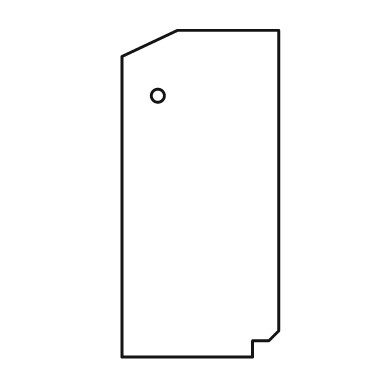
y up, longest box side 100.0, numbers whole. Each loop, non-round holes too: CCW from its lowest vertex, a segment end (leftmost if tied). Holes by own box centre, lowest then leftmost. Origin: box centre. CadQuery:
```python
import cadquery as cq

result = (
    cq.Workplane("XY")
    .moveTo(-24.0, -50.0)
    .lineTo(16.0, -50.0)
    .lineTo(16.0, -45.0)
    .lineTo(21.0, -45.0)
    .lineTo(24.0, -42.0)
    .lineTo(24.0, 50.0)
    .lineTo(-7.0, 50.0)
    .lineTo(-24.0, 42.0)
    .close()
    .moveTo(-13.0, 30.0)
    .circle(2.0)
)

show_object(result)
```